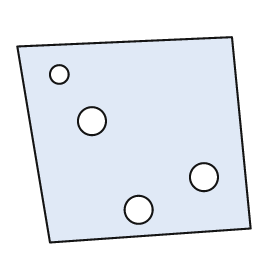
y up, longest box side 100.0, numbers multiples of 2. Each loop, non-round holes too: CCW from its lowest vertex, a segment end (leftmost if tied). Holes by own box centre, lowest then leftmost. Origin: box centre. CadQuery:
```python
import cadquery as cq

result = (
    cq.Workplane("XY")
    .moveTo(-36.0, -44.0)
    .lineTo(50.0, -38.0)
    .lineTo(42.0, 44.0)
    .lineTo(-50.0, 40.0)
    .close()
    .moveTo(2.0, -30.0)
    .circle(6.0)
    .moveTo(30.0, -16.0)
    .circle(6.0)
    .moveTo(-18.0, 8.0)
    .circle(6.0)
    .moveTo(-32.0, 28.0)
    .circle(4.0)
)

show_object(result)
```